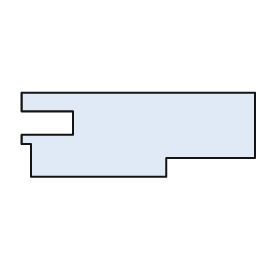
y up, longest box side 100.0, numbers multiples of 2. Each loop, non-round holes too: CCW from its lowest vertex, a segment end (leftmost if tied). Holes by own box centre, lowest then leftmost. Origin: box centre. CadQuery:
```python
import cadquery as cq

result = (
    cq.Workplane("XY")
    .moveTo(-46.0, -18.0)
    .lineTo(12.0, -18.0)
    .lineTo(12.0, -10.0)
    .lineTo(50.0, -10.0)
    .lineTo(50.0, 18.0)
    .lineTo(-50.0, 18.0)
    .lineTo(-50.0, 10.0)
    .lineTo(-28.0, 10.0)
    .lineTo(-28.0, 0.0)
    .lineTo(-50.0, 0.0)
    .lineTo(-50.0, -4.0)
    .lineTo(-46.0, -4.0)
    .close()
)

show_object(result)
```